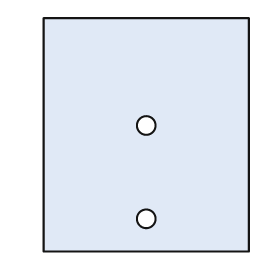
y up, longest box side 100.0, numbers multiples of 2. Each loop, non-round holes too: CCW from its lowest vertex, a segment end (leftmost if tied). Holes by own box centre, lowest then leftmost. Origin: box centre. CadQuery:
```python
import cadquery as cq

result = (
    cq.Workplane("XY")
    .moveTo(-44.0, -50.0)
    .lineTo(44.0, -50.0)
    .lineTo(44.0, 50.0)
    .lineTo(-44.0, 50.0)
    .close()
    .moveTo(0.0, -36.0)
    .circle(4.0)
    .moveTo(0.0, 4.0)
    .circle(4.0)
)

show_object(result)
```